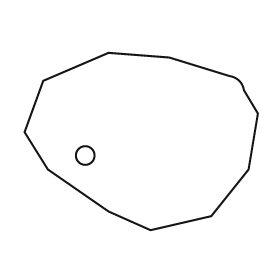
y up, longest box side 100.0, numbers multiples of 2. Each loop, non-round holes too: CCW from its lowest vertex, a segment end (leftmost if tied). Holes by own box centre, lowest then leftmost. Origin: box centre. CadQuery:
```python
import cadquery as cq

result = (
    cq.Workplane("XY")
    .moveTo(4.0, -38.0)
    .lineTo(30.0, -32.0)
    .lineTo(46.0, -12.0)
    .lineTo(50.0, 12.0)
    .lineTo(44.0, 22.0)
    .threePointArc((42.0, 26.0), (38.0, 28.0))
    .lineTo(12.0, 36.0)
    .lineTo(-14.0, 38.0)
    .lineTo(-42.0, 26.0)
    .lineTo(-50.0, 4.0)
    .lineTo(-40.0, -12.0)
    .lineTo(-14.0, -30.0)
    .close()
    .moveTo(-24.0, -6.0)
    .circle(4.0)
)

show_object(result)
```